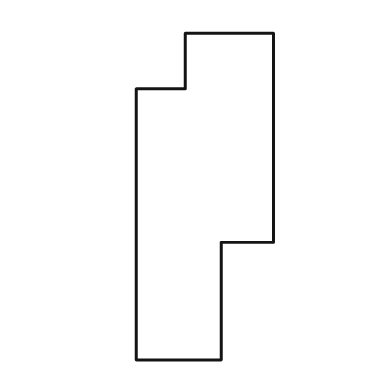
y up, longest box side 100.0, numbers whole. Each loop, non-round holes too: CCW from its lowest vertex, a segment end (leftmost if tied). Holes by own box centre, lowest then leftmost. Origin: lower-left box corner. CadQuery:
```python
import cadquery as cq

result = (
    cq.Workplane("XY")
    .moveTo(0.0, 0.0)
    .lineTo(26.0, 0.0)
    .lineTo(26.0, 36.0)
    .lineTo(42.0, 36.0)
    .lineTo(42.0, 100.0)
    .lineTo(15.0, 100.0)
    .lineTo(15.0, 83.0)
    .lineTo(0.0, 83.0)
    .close()
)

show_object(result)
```